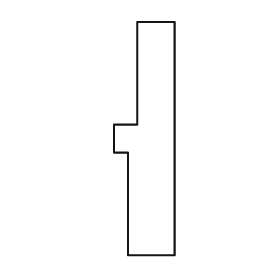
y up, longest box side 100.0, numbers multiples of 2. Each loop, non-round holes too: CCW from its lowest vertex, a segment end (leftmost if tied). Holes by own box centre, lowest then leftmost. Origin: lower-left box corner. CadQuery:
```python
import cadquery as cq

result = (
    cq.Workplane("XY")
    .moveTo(6.0, 0.0)
    .lineTo(26.0, 0.0)
    .lineTo(26.0, 100.0)
    .lineTo(10.0, 100.0)
    .lineTo(10.0, 56.0)
    .lineTo(0.0, 56.0)
    .lineTo(0.0, 44.0)
    .lineTo(6.0, 44.0)
    .close()
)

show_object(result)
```